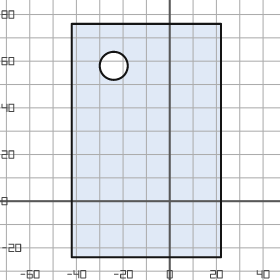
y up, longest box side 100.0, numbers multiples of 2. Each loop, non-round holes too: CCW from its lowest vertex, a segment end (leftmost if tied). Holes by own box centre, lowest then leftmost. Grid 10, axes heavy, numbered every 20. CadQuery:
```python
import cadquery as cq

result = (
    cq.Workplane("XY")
    .moveTo(-42.0, -24.0)
    .lineTo(22.0, -24.0)
    .lineTo(22.0, 76.0)
    .lineTo(-42.0, 76.0)
    .close()
    .moveTo(-24.0, 58.0)
    .circle(6.0)
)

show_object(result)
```